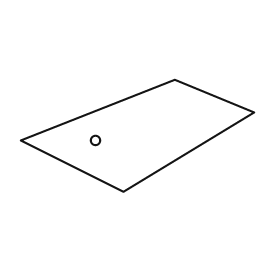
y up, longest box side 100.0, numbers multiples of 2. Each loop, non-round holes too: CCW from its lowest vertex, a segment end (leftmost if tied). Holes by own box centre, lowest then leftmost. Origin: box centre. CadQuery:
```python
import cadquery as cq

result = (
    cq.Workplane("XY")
    .moveTo(-6.0, -24.0)
    .lineTo(50.0, 10.0)
    .lineTo(16.0, 24.0)
    .lineTo(-50.0, -2.0)
    .close()
    .moveTo(-18.0, -2.0)
    .circle(2.0)
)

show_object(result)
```